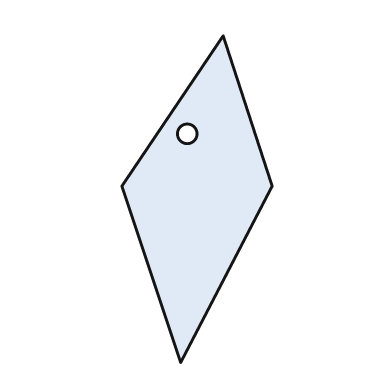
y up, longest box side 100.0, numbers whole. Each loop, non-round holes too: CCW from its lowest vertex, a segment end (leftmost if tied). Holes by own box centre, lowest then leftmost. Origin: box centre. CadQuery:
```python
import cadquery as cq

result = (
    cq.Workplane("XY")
    .moveTo(-5.0, -50.0)
    .lineTo(23.0, 4.0)
    .lineTo(8.0, 50.0)
    .lineTo(-23.0, 4.0)
    .close()
    .moveTo(-3.0, 20.0)
    .circle(3.0)
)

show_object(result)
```